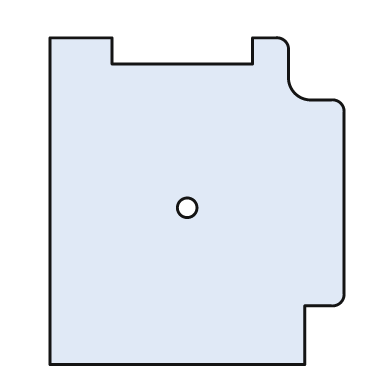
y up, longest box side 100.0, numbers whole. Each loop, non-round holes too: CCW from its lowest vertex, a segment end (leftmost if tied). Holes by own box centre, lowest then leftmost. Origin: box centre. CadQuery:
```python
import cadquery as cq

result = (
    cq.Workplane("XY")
    .moveTo(-45.0, -50.0)
    .lineTo(33.0, -50.0)
    .lineTo(33.0, -32.0)
    .lineTo(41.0, -32.0)
    .threePointArc((44.0, -31.0), (45.0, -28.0))
    .lineTo(45.0, 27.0)
    .threePointArc((44.0, 30.0), (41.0, 31.0))
    .lineTo(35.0, 31.0)
    .threePointArc((30.0, 33.0), (28.0, 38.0))
    .lineTo(28.0, 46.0)
    .threePointArc((27.0, 49.0), (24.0, 50.0))
    .lineTo(17.0, 50.0)
    .lineTo(17.0, 42.0)
    .lineTo(-26.0, 42.0)
    .lineTo(-26.0, 50.0)
    .lineTo(-45.0, 50.0)
    .close()
    .moveTo(-3.0, -2.0)
    .circle(3.0)
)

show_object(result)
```